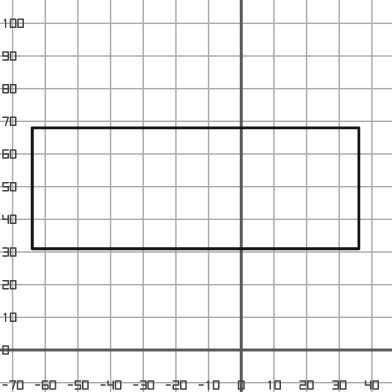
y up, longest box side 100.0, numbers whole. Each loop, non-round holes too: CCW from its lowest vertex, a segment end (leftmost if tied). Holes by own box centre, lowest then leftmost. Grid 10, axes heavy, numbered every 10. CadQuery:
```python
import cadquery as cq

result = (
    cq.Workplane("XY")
    .moveTo(-64.0, 31.0)
    .lineTo(36.0, 31.0)
    .lineTo(36.0, 68.0)
    .lineTo(-64.0, 68.0)
    .close()
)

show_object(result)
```